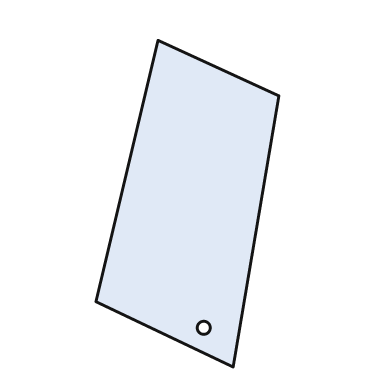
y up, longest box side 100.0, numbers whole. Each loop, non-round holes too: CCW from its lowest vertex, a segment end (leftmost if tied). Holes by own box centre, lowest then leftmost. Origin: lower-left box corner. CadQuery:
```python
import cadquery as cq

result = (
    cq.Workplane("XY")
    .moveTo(42.0, 0.0)
    .lineTo(56.0, 83.0)
    .lineTo(19.0, 100.0)
    .lineTo(0.0, 20.0)
    .close()
    .moveTo(33.0, 12.0)
    .circle(2.0)
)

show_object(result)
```